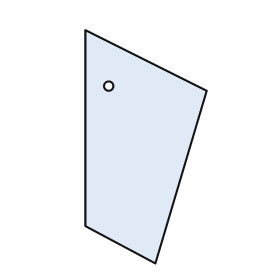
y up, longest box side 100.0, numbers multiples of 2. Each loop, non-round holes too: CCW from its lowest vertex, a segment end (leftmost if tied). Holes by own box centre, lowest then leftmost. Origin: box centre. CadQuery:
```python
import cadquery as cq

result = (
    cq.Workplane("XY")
    .moveTo(4.0, -50.0)
    .lineTo(26.0, 24.0)
    .lineTo(-26.0, 50.0)
    .lineTo(-26.0, -34.0)
    .close()
    .moveTo(-16.0, 26.0)
    .circle(2.0)
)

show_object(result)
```